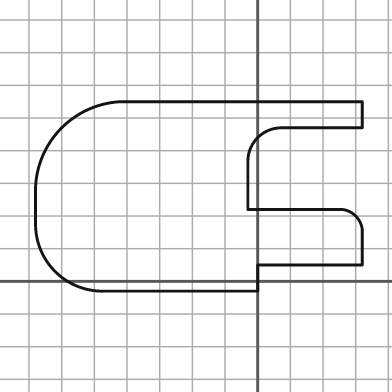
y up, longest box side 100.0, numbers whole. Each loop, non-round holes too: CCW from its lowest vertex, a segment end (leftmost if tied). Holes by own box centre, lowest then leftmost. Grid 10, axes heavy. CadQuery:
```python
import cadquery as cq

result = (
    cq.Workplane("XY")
    .moveTo(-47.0, -3.0)
    .lineTo(0.0, -3.0)
    .lineTo(0.0, 5.0)
    .lineTo(32.0, 5.0)
    .lineTo(32.0, 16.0)
    .threePointArc((30.0, 20.0), (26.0, 22.0))
    .lineTo(-3.0, 22.0)
    .lineTo(-3.0, 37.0)
    .threePointArc((0.0, 44.0), (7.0, 47.0))
    .lineTo(32.0, 47.0)
    .lineTo(32.0, 55.0)
    .lineTo(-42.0, 55.0)
    .threePointArc((-60.0, 47.0), (-68.0, 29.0))
    .lineTo(-68.0, 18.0)
    .threePointArc((-62.0, 3.0), (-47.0, -3.0))
    .close()
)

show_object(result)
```